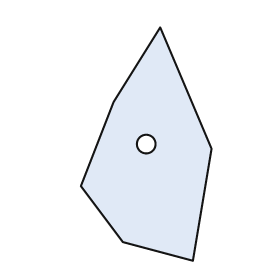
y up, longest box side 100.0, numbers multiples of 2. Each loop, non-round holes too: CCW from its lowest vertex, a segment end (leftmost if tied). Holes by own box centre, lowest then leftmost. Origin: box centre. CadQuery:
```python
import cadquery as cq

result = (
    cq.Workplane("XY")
    .moveTo(20.0, -50.0)
    .lineTo(28.0, -2.0)
    .lineTo(6.0, 50.0)
    .lineTo(-14.0, 18.0)
    .lineTo(-28.0, -18.0)
    .lineTo(-10.0, -42.0)
    .close()
    .moveTo(0.0, 0.0)
    .circle(4.0)
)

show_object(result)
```